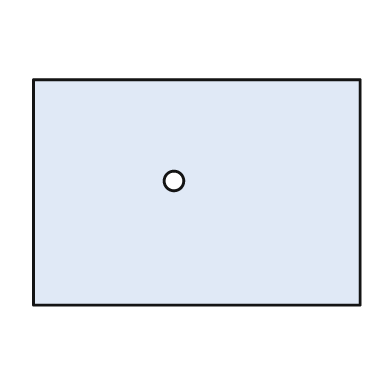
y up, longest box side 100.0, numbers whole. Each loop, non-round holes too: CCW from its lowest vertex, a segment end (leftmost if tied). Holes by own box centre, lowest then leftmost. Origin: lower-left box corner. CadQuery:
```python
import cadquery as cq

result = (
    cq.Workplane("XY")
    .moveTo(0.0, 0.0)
    .lineTo(100.0, 0.0)
    .lineTo(100.0, 69.0)
    .lineTo(0.0, 69.0)
    .close()
    .moveTo(43.0, 38.0)
    .circle(3.0)
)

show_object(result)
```